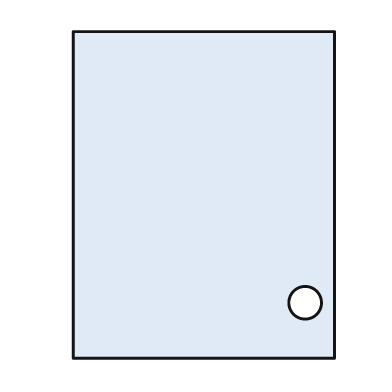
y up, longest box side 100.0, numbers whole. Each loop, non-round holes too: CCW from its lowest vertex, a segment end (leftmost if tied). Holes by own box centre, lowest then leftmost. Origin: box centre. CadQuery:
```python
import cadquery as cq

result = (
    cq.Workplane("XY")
    .moveTo(-40.0, -50.0)
    .lineTo(40.0, -50.0)
    .lineTo(40.0, 50.0)
    .lineTo(-40.0, 50.0)
    .close()
    .moveTo(31.0, -33.0)
    .circle(5.0)
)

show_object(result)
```